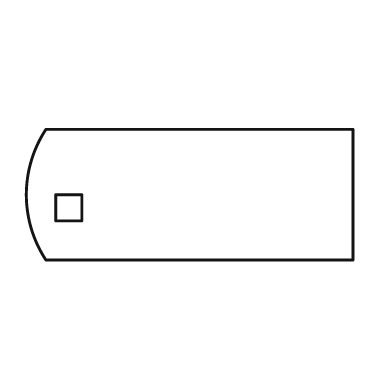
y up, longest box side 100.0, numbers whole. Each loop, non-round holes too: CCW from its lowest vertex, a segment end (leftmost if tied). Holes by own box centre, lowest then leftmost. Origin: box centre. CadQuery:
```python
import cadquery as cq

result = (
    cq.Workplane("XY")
    .moveTo(-44.0, -20.0)
    .lineTo(50.0, -20.0)
    .lineTo(50.0, 20.0)
    .lineTo(-44.0, 20.0)
    .threePointArc((-50.0, 0.0), (-44.0, -20.0))
    .close()
    .moveTo(-41.0, -8.0)
    .lineTo(-33.0, -8.0)
    .lineTo(-33.0, 0.0)
    .lineTo(-41.0, 0.0)
    .close()
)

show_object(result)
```